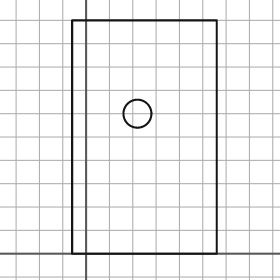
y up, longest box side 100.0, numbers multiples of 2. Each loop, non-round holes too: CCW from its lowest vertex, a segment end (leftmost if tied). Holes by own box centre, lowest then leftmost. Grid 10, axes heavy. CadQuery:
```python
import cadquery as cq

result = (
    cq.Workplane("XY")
    .moveTo(-6.0, 0.0)
    .lineTo(56.0, 0.0)
    .lineTo(56.0, 100.0)
    .lineTo(-6.0, 100.0)
    .close()
    .moveTo(22.0, 60.0)
    .circle(6.0)
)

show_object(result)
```